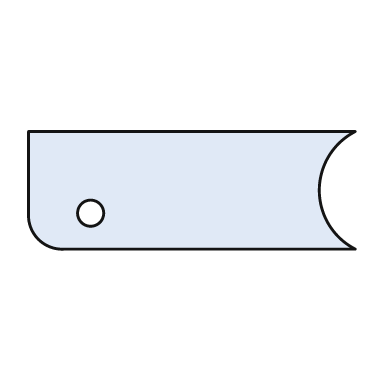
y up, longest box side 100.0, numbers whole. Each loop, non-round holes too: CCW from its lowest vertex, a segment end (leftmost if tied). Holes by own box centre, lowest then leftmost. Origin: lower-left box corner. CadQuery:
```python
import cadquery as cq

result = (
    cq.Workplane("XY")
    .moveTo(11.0, 0.0)
    .lineTo(100.0, 0.0)
    .threePointArc((89.0, 18.0), (100.0, 36.0))
    .lineTo(0.0, 36.0)
    .lineTo(0.0, 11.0)
    .threePointArc((3.0, 3.0), (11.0, 0.0))
    .close()
    .moveTo(19.0, 11.0)
    .circle(4.0)
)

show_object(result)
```